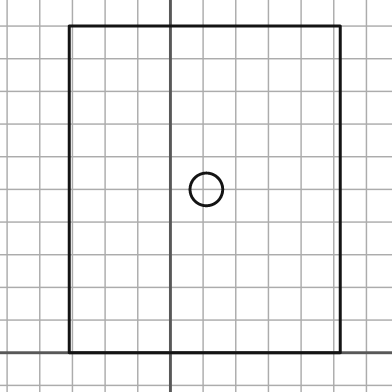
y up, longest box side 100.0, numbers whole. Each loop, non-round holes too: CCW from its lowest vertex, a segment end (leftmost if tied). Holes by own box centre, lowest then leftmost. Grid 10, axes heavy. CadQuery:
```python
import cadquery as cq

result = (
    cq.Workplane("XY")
    .moveTo(-31.0, 0.0)
    .lineTo(52.0, 0.0)
    .lineTo(52.0, 100.0)
    .lineTo(-31.0, 100.0)
    .close()
    .moveTo(11.0, 50.0)
    .circle(5.0)
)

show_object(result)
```